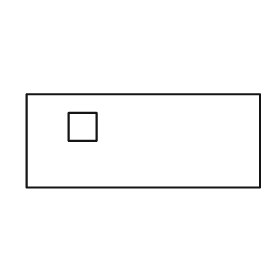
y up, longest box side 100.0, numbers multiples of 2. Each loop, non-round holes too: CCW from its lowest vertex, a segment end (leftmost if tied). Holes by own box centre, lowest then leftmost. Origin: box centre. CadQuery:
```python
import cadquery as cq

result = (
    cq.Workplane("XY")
    .moveTo(-50.0, -20.0)
    .lineTo(50.0, -20.0)
    .lineTo(50.0, 20.0)
    .lineTo(-50.0, 20.0)
    .close()
    .moveTo(-32.0, 0.0)
    .lineTo(-20.0, 0.0)
    .lineTo(-20.0, 12.0)
    .lineTo(-32.0, 12.0)
    .close()
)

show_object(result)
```